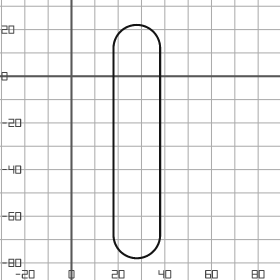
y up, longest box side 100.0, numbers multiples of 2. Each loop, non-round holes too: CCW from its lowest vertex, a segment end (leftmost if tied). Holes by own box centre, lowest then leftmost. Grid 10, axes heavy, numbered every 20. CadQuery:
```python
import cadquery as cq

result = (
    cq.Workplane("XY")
    .moveTo(18.0, -68.0)
    .threePointArc((28.0, -78.0), (38.0, -68.0))
    .lineTo(38.0, 12.0)
    .threePointArc((28.0, 22.0), (18.0, 12.0))
    .close()
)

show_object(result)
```